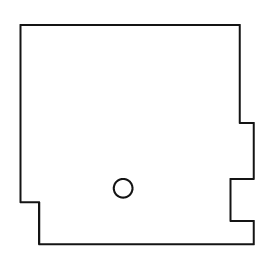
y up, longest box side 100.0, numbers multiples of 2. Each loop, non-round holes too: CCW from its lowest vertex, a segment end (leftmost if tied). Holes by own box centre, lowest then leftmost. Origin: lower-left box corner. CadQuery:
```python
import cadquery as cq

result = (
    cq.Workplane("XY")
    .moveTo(8.0, 0.0)
    .lineTo(100.0, 0.0)
    .lineTo(100.0, 10.0)
    .lineTo(90.0, 10.0)
    .lineTo(90.0, 28.0)
    .lineTo(100.0, 28.0)
    .lineTo(100.0, 52.0)
    .lineTo(94.0, 52.0)
    .lineTo(94.0, 94.0)
    .lineTo(0.0, 94.0)
    .lineTo(0.0, 18.0)
    .lineTo(8.0, 18.0)
    .close()
    .moveTo(44.0, 24.0)
    .circle(4.0)
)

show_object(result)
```